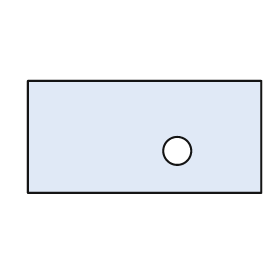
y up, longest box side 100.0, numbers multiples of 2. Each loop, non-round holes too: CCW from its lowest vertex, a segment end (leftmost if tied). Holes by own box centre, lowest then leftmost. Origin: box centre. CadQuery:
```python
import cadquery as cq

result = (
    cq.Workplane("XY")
    .moveTo(-50.0, -24.0)
    .lineTo(50.0, -24.0)
    .lineTo(50.0, 24.0)
    .lineTo(-50.0, 24.0)
    .close()
    .moveTo(14.0, -6.0)
    .circle(6.0)
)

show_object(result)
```